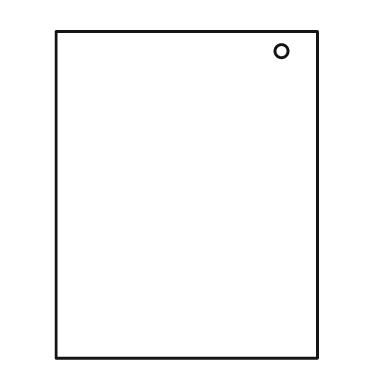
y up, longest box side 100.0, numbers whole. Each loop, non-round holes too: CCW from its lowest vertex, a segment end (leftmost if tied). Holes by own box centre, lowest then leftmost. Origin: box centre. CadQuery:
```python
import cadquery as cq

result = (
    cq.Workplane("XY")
    .moveTo(-40.0, -50.0)
    .lineTo(40.0, -50.0)
    .lineTo(40.0, 50.0)
    .lineTo(-40.0, 50.0)
    .close()
    .moveTo(29.0, 44.0)
    .circle(2.0)
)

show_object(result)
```